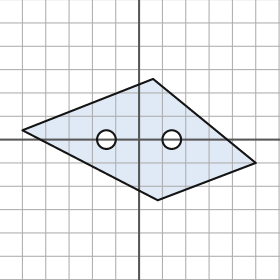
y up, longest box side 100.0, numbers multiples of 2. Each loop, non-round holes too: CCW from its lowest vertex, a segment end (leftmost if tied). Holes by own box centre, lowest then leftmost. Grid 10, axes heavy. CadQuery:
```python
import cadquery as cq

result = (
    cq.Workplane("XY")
    .moveTo(8.0, -26.0)
    .lineTo(50.0, -10.0)
    .lineTo(6.0, 26.0)
    .lineTo(-50.0, 4.0)
    .close()
    .moveTo(-14.0, 0.0)
    .circle(4.0)
    .moveTo(14.0, 0.0)
    .circle(4.0)
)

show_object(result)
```